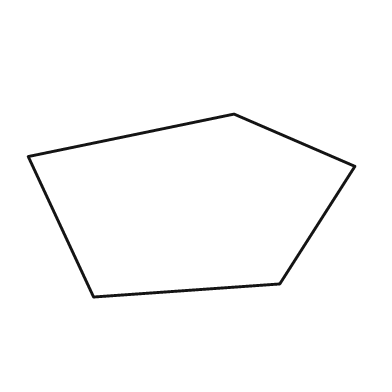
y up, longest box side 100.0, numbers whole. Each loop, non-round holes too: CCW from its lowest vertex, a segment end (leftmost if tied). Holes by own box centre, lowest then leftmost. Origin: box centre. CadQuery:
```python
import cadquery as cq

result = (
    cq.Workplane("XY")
    .moveTo(-30.0, -28.0)
    .lineTo(27.0, -24.0)
    .lineTo(50.0, 12.0)
    .lineTo(13.0, 28.0)
    .lineTo(-50.0, 15.0)
    .close()
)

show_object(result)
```